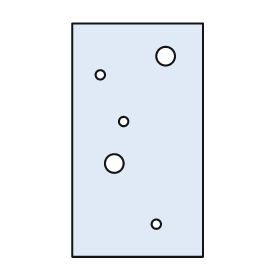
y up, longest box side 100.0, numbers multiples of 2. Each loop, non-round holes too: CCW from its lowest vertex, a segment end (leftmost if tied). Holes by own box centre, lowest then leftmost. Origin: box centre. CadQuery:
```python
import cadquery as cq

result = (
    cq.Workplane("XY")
    .moveTo(-28.0, -50.0)
    .lineTo(28.0, -50.0)
    .lineTo(28.0, 50.0)
    .lineTo(-28.0, 50.0)
    .close()
    .moveTo(8.0, -36.0)
    .circle(2.0)
    .moveTo(-10.0, -10.0)
    .circle(4.0)
    .moveTo(-6.0, 8.0)
    .circle(2.0)
    .moveTo(-16.0, 28.0)
    .circle(2.0)
    .moveTo(12.0, 36.0)
    .circle(4.0)
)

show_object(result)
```